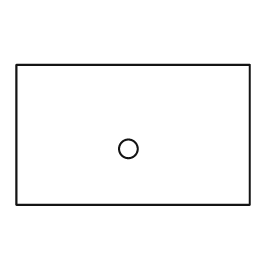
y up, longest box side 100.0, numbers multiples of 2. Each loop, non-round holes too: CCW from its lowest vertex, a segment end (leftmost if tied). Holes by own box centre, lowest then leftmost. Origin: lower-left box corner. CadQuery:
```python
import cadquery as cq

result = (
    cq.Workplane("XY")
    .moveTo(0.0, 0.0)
    .lineTo(100.0, 0.0)
    .lineTo(100.0, 60.0)
    .lineTo(0.0, 60.0)
    .close()
    .moveTo(48.0, 24.0)
    .circle(4.0)
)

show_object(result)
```